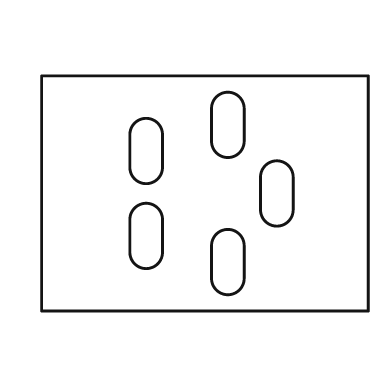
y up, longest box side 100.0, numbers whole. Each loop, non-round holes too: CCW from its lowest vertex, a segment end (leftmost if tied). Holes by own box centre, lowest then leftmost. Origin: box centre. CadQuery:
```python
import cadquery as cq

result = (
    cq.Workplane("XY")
    .moveTo(-50.0, -36.0)
    .lineTo(50.0, -36.0)
    .lineTo(50.0, 36.0)
    .lineTo(-50.0, 36.0)
    .close()
    .moveTo(2.0, -26.0)
    .threePointArc((7.0, -31.0), (12.0, -26.0))
    .lineTo(12.0, -16.0)
    .threePointArc((7.0, -11.0), (2.0, -16.0))
    .close()
    .moveTo(-23.0, -18.0)
    .threePointArc((-18.0, -23.0), (-13.0, -18.0))
    .lineTo(-13.0, -8.0)
    .threePointArc((-18.0, -3.0), (-23.0, -8.0))
    .close()
    .moveTo(17.0, -5.0)
    .threePointArc((22.0, -10.0), (27.0, -5.0))
    .lineTo(27.0, 5.0)
    .threePointArc((22.0, 10.0), (17.0, 5.0))
    .close()
    .moveTo(-23.0, 8.0)
    .threePointArc((-18.0, 3.0), (-13.0, 8.0))
    .lineTo(-13.0, 18.0)
    .threePointArc((-18.0, 23.0), (-23.0, 18.0))
    .close()
    .moveTo(2.0, 16.0)
    .threePointArc((7.0, 11.0), (12.0, 16.0))
    .lineTo(12.0, 26.0)
    .threePointArc((7.0, 31.0), (2.0, 26.0))
    .close()
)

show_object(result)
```